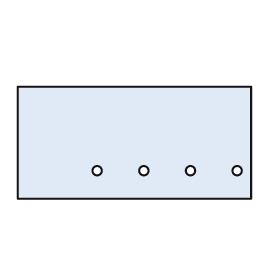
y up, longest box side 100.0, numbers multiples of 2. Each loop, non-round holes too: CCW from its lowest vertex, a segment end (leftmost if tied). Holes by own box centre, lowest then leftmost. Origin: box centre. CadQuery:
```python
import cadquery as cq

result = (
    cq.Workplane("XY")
    .moveTo(-50.0, -24.0)
    .lineTo(50.0, -24.0)
    .lineTo(50.0, 24.0)
    .lineTo(-50.0, 24.0)
    .close()
    .moveTo(-16.0, -12.0)
    .circle(2.0)
    .moveTo(4.0, -12.0)
    .circle(2.0)
    .moveTo(24.0, -12.0)
    .circle(2.0)
    .moveTo(44.0, -12.0)
    .circle(2.0)
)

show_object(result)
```